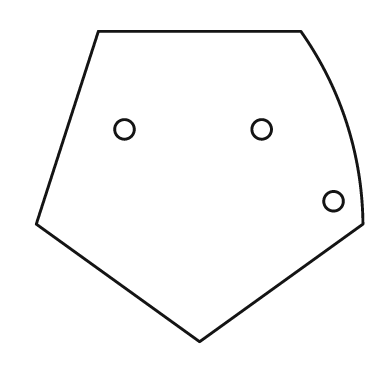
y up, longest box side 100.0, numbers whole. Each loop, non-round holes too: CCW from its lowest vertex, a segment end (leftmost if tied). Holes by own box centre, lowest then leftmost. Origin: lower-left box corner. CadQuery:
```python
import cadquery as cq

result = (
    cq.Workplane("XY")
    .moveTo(50.0, 0.0)
    .lineTo(100.0, 36.0)
    .threePointArc((95.0, 67.0), (81.0, 95.0))
    .lineTo(19.0, 95.0)
    .lineTo(0.0, 36.0)
    .close()
    .moveTo(91.0, 43.0)
    .circle(3.0)
    .moveTo(27.0, 65.0)
    .circle(3.0)
    .moveTo(69.0, 65.0)
    .circle(3.0)
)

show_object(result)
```